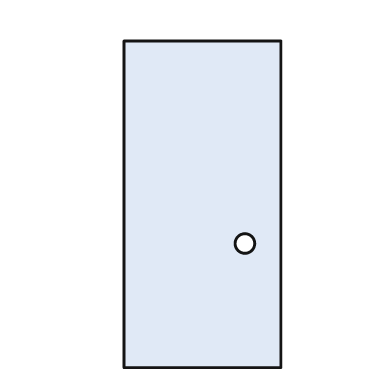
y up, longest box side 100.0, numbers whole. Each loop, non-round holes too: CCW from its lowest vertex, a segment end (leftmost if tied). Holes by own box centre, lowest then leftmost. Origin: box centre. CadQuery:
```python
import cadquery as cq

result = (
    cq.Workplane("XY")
    .moveTo(-24.0, -50.0)
    .lineTo(24.0, -50.0)
    .lineTo(24.0, 50.0)
    .lineTo(-24.0, 50.0)
    .close()
    .moveTo(13.0, -12.0)
    .circle(3.0)
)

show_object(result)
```